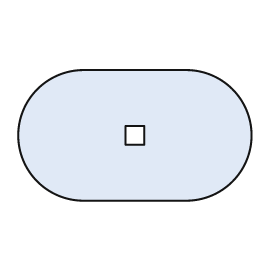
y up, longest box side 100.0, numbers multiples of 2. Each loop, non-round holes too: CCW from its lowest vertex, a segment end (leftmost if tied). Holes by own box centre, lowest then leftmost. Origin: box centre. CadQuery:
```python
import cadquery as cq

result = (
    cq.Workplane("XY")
    .moveTo(-22.0, -28.0)
    .lineTo(22.0, -28.0)
    .threePointArc((50.0, 0.0), (22.0, 28.0))
    .lineTo(-22.0, 28.0)
    .threePointArc((-50.0, 0.0), (-22.0, -28.0))
    .close()
    .moveTo(-4.0, -4.0)
    .lineTo(4.0, -4.0)
    .lineTo(4.0, 4.0)
    .lineTo(-4.0, 4.0)
    .close()
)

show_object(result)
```